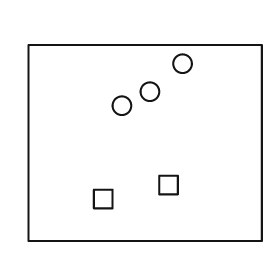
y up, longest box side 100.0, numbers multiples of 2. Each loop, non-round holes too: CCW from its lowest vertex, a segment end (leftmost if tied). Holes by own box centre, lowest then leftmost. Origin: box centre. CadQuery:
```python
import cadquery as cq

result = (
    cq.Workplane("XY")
    .moveTo(-50.0, -42.0)
    .lineTo(50.0, -42.0)
    .lineTo(50.0, 42.0)
    .lineTo(-50.0, 42.0)
    .close()
    .moveTo(-22.0, -28.0)
    .lineTo(-14.0, -28.0)
    .lineTo(-14.0, -20.0)
    .lineTo(-22.0, -20.0)
    .close()
    .moveTo(6.0, -22.0)
    .lineTo(14.0, -22.0)
    .lineTo(14.0, -14.0)
    .lineTo(6.0, -14.0)
    .close()
    .moveTo(-10.0, 16.0)
    .circle(4.0)
    .moveTo(2.0, 22.0)
    .circle(4.0)
    .moveTo(16.0, 34.0)
    .circle(4.0)
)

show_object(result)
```